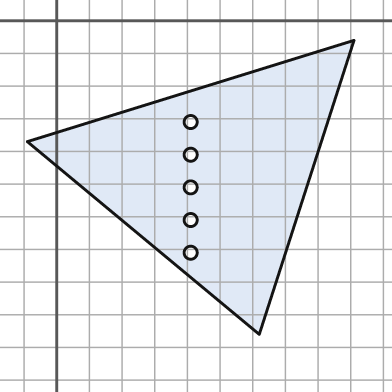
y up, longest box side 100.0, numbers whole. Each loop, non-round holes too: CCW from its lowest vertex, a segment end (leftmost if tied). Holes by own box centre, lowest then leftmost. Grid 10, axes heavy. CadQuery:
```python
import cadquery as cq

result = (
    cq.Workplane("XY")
    .moveTo(62.0, -96.0)
    .lineTo(91.0, -6.0)
    .lineTo(-9.0, -37.0)
    .close()
    .moveTo(41.0, -71.0)
    .circle(2.0)
    .moveTo(41.0, -61.0)
    .circle(2.0)
    .moveTo(41.0, -51.0)
    .circle(2.0)
    .moveTo(41.0, -41.0)
    .circle(2.0)
    .moveTo(41.0, -31.0)
    .circle(2.0)
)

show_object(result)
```